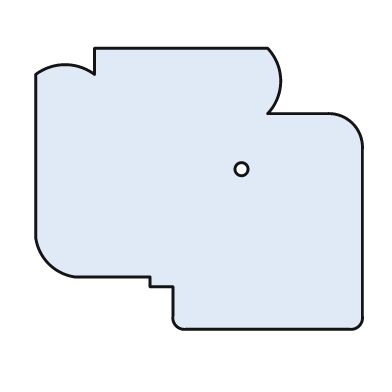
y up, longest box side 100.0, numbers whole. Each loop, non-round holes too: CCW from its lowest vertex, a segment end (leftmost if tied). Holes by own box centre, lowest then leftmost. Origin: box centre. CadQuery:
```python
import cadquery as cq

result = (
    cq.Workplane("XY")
    .moveTo(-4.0, -43.0)
    .lineTo(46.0, -43.0)
    .threePointArc((49.0, -42.0), (50.0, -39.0))
    .lineTo(50.0, 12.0)
    .threePointArc((47.0, 20.0), (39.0, 23.0))
    .lineTo(21.0, 23.0)
    .threePointArc((25.0, 33.0), (21.0, 43.0))
    .lineTo(-32.0, 43.0)
    .lineTo(-32.0, 35.0)
    .threePointArc((-41.0, 38.0), (-50.0, 35.0))
    .lineTo(-50.0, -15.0)
    .threePointArc((-46.0, -23.0), (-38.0, -27.0))
    .lineTo(-15.0, -27.0)
    .lineTo(-15.0, -30.0)
    .lineTo(-8.0, -30.0)
    .lineTo(-8.0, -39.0)
    .threePointArc((-7.0, -42.0), (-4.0, -43.0))
    .close()
    .moveTo(13.0, 6.0)
    .circle(2.0)
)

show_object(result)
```